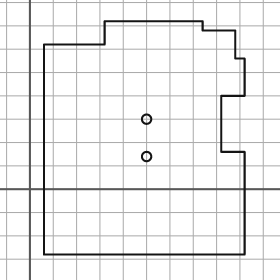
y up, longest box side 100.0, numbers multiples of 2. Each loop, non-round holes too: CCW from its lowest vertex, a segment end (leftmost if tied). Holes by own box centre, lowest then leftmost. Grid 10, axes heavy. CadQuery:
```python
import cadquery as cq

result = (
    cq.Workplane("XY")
    .moveTo(6.0, -28.0)
    .lineTo(92.0, -28.0)
    .lineTo(92.0, 16.0)
    .lineTo(82.0, 16.0)
    .lineTo(82.0, 40.0)
    .lineTo(92.0, 40.0)
    .lineTo(92.0, 56.0)
    .lineTo(88.0, 56.0)
    .lineTo(88.0, 68.0)
    .lineTo(74.0, 68.0)
    .lineTo(74.0, 72.0)
    .lineTo(32.0, 72.0)
    .lineTo(32.0, 62.0)
    .lineTo(6.0, 62.0)
    .close()
    .moveTo(50.0, 14.0)
    .circle(2.0)
    .moveTo(50.0, 30.0)
    .circle(2.0)
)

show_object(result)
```